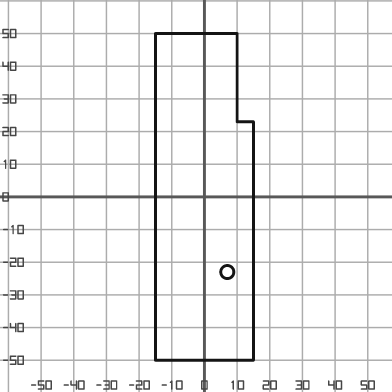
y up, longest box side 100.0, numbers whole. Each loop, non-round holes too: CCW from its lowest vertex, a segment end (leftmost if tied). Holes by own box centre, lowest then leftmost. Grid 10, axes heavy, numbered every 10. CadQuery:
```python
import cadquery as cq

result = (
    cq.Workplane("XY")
    .moveTo(-15.0, -50.0)
    .lineTo(15.0, -50.0)
    .lineTo(15.0, 23.0)
    .lineTo(10.0, 23.0)
    .lineTo(10.0, 50.0)
    .lineTo(-15.0, 50.0)
    .close()
    .moveTo(7.0, -23.0)
    .circle(2.0)
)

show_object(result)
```